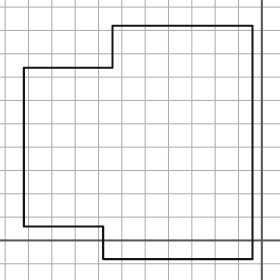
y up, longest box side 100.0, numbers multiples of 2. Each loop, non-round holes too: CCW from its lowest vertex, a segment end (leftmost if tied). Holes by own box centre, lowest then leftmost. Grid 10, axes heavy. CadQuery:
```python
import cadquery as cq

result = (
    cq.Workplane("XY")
    .moveTo(-68.0, -8.0)
    .lineTo(-4.0, -8.0)
    .lineTo(-4.0, 92.0)
    .lineTo(-64.0, 92.0)
    .lineTo(-64.0, 74.0)
    .lineTo(-102.0, 74.0)
    .lineTo(-102.0, 6.0)
    .lineTo(-68.0, 6.0)
    .close()
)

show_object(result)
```